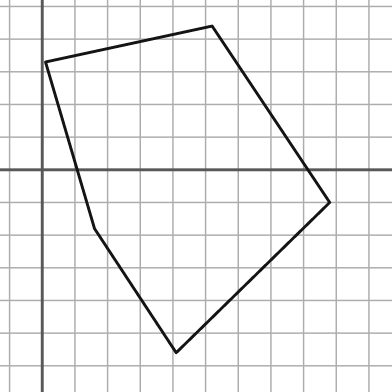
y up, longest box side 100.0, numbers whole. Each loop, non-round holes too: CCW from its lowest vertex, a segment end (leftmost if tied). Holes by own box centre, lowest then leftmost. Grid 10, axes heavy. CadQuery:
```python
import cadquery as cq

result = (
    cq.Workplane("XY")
    .moveTo(41.0, -56.0)
    .lineTo(88.0, -10.0)
    .lineTo(52.0, 44.0)
    .lineTo(1.0, 33.0)
    .lineTo(16.0, -18.0)
    .close()
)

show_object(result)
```